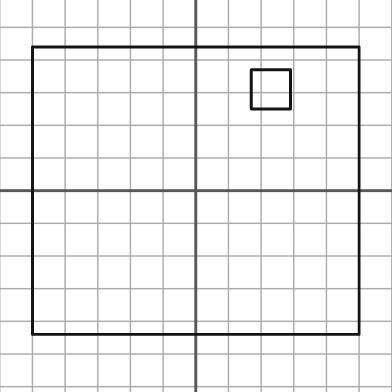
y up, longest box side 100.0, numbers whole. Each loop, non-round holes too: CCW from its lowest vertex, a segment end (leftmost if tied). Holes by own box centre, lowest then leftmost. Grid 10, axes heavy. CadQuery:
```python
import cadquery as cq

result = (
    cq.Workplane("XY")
    .moveTo(-50.0, -44.0)
    .lineTo(50.0, -44.0)
    .lineTo(50.0, 44.0)
    .lineTo(-50.0, 44.0)
    .close()
    .moveTo(17.0, 25.0)
    .lineTo(29.0, 25.0)
    .lineTo(29.0, 37.0)
    .lineTo(17.0, 37.0)
    .close()
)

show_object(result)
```